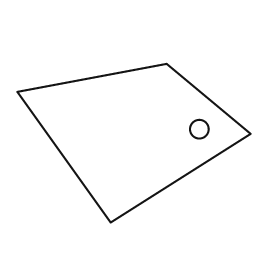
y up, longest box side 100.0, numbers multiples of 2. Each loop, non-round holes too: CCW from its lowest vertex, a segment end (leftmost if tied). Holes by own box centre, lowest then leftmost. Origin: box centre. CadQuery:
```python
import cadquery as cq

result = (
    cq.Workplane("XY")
    .moveTo(-10.0, -34.0)
    .lineTo(50.0, 4.0)
    .lineTo(14.0, 34.0)
    .lineTo(-50.0, 22.0)
    .close()
    .moveTo(28.0, 6.0)
    .circle(4.0)
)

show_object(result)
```